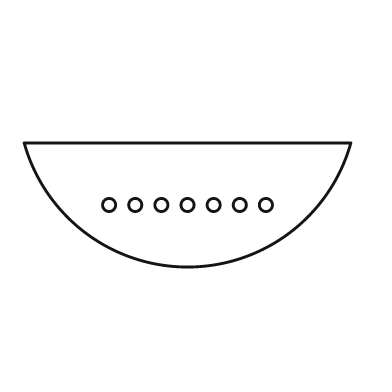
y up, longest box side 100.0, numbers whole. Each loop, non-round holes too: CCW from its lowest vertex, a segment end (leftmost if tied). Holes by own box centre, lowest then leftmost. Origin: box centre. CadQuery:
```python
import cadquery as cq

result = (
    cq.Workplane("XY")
    .moveTo(-50.0, 19.0)
    .threePointArc((0.0, -19.0), (50.0, 19.0))
    .close()
    .moveTo(-24.0, 0.0)
    .circle(2.0)
    .moveTo(-16.0, 0.0)
    .circle(2.0)
    .moveTo(-8.0, 0.0)
    .circle(2.0)
    .moveTo(0.0, 0.0)
    .circle(2.0)
    .moveTo(8.0, 0.0)
    .circle(2.0)
    .moveTo(16.0, 0.0)
    .circle(2.0)
    .moveTo(24.0, 0.0)
    .circle(2.0)
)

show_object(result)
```